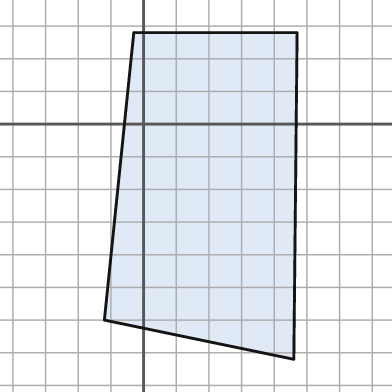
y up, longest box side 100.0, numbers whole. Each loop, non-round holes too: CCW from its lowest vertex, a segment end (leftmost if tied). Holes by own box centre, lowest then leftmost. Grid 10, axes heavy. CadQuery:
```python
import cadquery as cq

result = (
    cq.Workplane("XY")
    .moveTo(46.0, -72.0)
    .lineTo(47.0, 28.0)
    .lineTo(-3.0, 28.0)
    .lineTo(-12.0, -60.0)
    .close()
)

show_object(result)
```